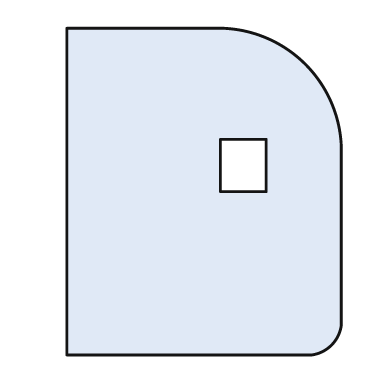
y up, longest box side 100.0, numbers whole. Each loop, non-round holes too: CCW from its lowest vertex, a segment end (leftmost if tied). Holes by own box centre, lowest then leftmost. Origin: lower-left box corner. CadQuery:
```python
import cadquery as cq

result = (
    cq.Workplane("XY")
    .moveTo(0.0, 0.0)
    .lineTo(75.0, 0.0)
    .threePointArc((81.0, 3.0), (84.0, 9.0))
    .lineTo(84.0, 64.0)
    .threePointArc((73.0, 89.0), (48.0, 100.0))
    .lineTo(0.0, 100.0)
    .close()
    .moveTo(47.0, 50.0)
    .lineTo(61.0, 50.0)
    .lineTo(61.0, 66.0)
    .lineTo(47.0, 66.0)
    .close()
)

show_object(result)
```